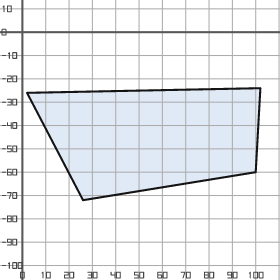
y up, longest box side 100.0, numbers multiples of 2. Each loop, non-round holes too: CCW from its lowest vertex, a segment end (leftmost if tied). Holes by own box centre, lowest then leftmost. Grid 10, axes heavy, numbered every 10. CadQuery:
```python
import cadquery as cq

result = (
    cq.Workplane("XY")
    .moveTo(26.0, -72.0)
    .lineTo(100.0, -60.0)
    .lineTo(102.0, -24.0)
    .lineTo(2.0, -26.0)
    .close()
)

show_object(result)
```